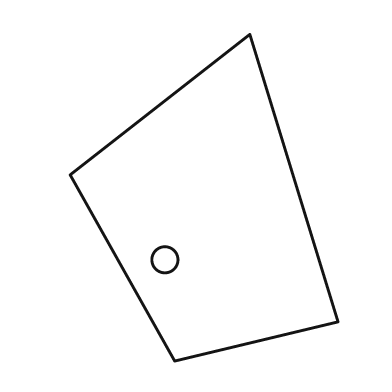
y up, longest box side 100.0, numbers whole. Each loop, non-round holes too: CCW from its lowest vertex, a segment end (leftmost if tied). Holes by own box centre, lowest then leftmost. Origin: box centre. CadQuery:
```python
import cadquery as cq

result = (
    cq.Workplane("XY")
    .moveTo(-9.0, -50.0)
    .lineTo(41.0, -38.0)
    .lineTo(14.0, 50.0)
    .lineTo(-41.0, 7.0)
    .close()
    .moveTo(-12.0, -19.0)
    .circle(4.0)
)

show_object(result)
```